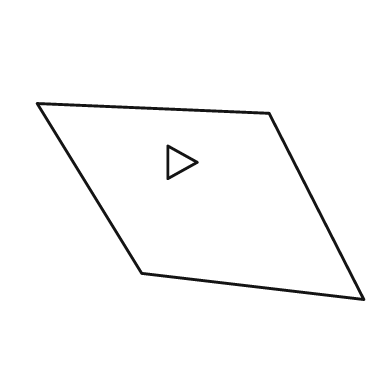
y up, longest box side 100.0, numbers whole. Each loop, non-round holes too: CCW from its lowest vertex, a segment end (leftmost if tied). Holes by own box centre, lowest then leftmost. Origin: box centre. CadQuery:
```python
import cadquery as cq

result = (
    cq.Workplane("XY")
    .moveTo(50.0, -30.0)
    .lineTo(21.0, 27.0)
    .lineTo(-50.0, 30.0)
    .lineTo(-18.0, -22.0)
    .close()
    .moveTo(-10.0, 7.0)
    .lineTo(-1.0, 12.0)
    .lineTo(-10.0, 17.0)
    .close()
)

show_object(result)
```